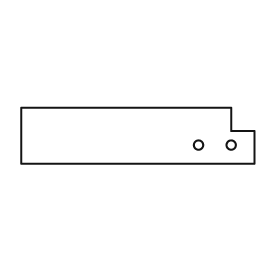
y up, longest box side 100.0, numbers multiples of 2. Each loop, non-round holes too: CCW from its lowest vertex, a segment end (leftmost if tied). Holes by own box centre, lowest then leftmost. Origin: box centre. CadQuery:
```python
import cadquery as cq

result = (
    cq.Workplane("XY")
    .moveTo(-50.0, -12.0)
    .lineTo(50.0, -12.0)
    .lineTo(50.0, 2.0)
    .lineTo(40.0, 2.0)
    .lineTo(40.0, 12.0)
    .lineTo(-50.0, 12.0)
    .close()
    .moveTo(26.0, -4.0)
    .circle(2.0)
    .moveTo(40.0, -4.0)
    .circle(2.0)
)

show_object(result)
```